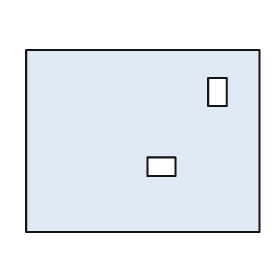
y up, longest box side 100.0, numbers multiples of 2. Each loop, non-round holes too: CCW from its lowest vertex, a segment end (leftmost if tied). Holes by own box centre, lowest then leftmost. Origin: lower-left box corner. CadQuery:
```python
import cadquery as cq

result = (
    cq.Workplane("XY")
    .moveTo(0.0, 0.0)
    .lineTo(100.0, 0.0)
    .lineTo(100.0, 78.0)
    .lineTo(0.0, 78.0)
    .close()
    .moveTo(52.0, 24.0)
    .lineTo(64.0, 24.0)
    .lineTo(64.0, 32.0)
    .lineTo(52.0, 32.0)
    .close()
    .moveTo(78.0, 54.0)
    .lineTo(86.0, 54.0)
    .lineTo(86.0, 66.0)
    .lineTo(78.0, 66.0)
    .close()
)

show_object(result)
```